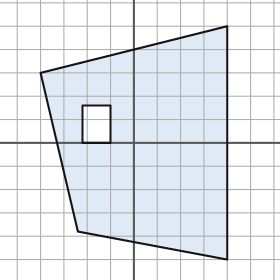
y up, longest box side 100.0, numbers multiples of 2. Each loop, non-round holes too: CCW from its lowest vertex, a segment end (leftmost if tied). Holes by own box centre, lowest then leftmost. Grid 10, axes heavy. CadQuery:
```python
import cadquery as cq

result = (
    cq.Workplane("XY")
    .moveTo(40.0, -50.0)
    .lineTo(40.0, 50.0)
    .lineTo(-40.0, 30.0)
    .lineTo(-24.0, -38.0)
    .close()
    .moveTo(-22.0, 0.0)
    .lineTo(-10.0, 0.0)
    .lineTo(-10.0, 16.0)
    .lineTo(-22.0, 16.0)
    .close()
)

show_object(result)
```